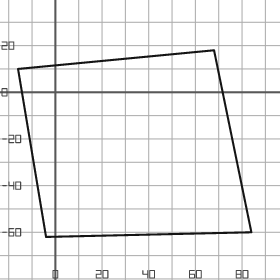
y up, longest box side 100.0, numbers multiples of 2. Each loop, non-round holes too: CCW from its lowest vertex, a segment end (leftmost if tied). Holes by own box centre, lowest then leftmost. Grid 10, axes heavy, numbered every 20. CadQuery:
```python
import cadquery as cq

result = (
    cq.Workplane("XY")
    .moveTo(-4.0, -62.0)
    .lineTo(84.0, -60.0)
    .lineTo(68.0, 18.0)
    .lineTo(-16.0, 10.0)
    .close()
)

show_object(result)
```